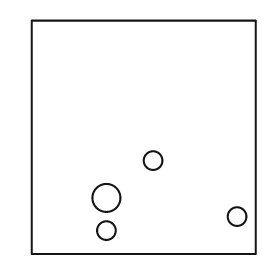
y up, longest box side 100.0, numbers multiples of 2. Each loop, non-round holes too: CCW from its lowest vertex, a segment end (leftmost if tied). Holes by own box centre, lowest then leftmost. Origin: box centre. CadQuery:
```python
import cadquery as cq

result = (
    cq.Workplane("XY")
    .moveTo(-48.0, -50.0)
    .lineTo(48.0, -50.0)
    .lineTo(48.0, 50.0)
    .lineTo(-48.0, 50.0)
    .close()
    .moveTo(-16.0, -40.0)
    .circle(4.0)
    .moveTo(40.0, -34.0)
    .circle(4.0)
    .moveTo(-16.0, -26.0)
    .circle(6.0)
    .moveTo(4.0, -10.0)
    .circle(4.0)
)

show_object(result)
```